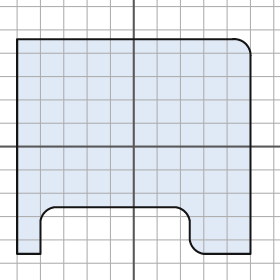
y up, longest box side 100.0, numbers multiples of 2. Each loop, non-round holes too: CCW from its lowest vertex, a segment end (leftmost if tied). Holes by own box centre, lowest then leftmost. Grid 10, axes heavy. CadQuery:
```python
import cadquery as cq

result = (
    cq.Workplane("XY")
    .moveTo(-50.0, -46.0)
    .lineTo(-40.0, -46.0)
    .lineTo(-40.0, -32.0)
    .threePointArc((-38.0, -28.0), (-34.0, -26.0))
    .lineTo(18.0, -26.0)
    .threePointArc((22.0, -28.0), (24.0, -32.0))
    .lineTo(24.0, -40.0)
    .threePointArc((26.0, -44.0), (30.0, -46.0))
    .lineTo(50.0, -46.0)
    .lineTo(50.0, 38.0)
    .threePointArc((48.0, 44.0), (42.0, 46.0))
    .lineTo(-50.0, 46.0)
    .close()
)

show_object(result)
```